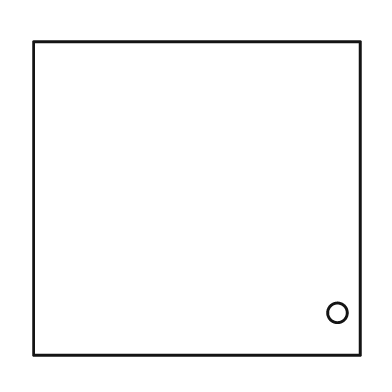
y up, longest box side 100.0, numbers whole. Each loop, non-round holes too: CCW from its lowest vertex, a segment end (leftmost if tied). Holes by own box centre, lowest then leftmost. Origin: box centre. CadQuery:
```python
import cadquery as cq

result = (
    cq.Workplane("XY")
    .moveTo(-50.0, -48.0)
    .lineTo(50.0, -48.0)
    .lineTo(50.0, 48.0)
    .lineTo(-50.0, 48.0)
    .close()
    .moveTo(43.0, -35.0)
    .circle(3.0)
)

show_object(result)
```